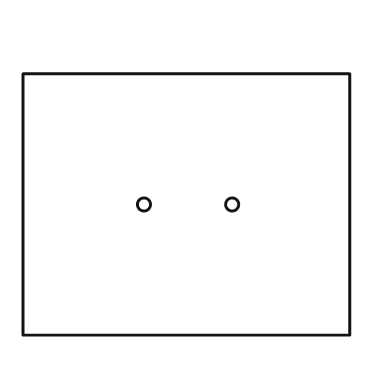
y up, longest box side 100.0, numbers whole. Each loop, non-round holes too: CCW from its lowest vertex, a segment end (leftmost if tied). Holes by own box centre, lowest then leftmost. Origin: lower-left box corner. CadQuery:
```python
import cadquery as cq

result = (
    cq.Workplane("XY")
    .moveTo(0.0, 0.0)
    .lineTo(100.0, 0.0)
    .lineTo(100.0, 80.0)
    .lineTo(0.0, 80.0)
    .close()
    .moveTo(37.0, 40.0)
    .circle(2.0)
    .moveTo(64.0, 40.0)
    .circle(2.0)
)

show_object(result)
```